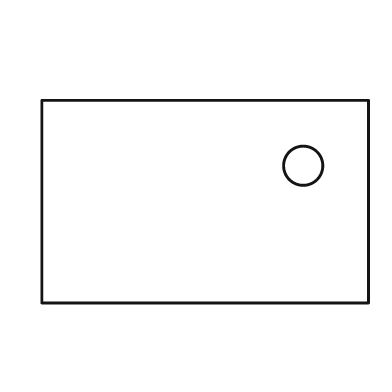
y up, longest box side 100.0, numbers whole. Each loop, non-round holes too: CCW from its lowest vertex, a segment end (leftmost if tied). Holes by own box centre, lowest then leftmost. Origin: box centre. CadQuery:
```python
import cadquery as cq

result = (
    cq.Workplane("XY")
    .moveTo(-50.0, -31.0)
    .lineTo(50.0, -31.0)
    .lineTo(50.0, 31.0)
    .lineTo(-50.0, 31.0)
    .close()
    .moveTo(30.0, 11.0)
    .circle(6.0)
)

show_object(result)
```